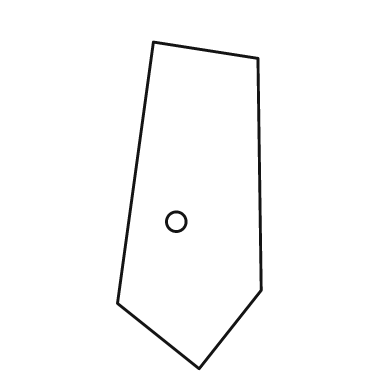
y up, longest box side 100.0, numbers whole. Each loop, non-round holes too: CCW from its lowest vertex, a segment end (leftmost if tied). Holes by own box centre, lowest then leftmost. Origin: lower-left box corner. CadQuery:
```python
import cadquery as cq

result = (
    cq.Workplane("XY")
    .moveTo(25.0, 0.0)
    .lineTo(44.0, 24.0)
    .lineTo(43.0, 95.0)
    .lineTo(11.0, 100.0)
    .lineTo(0.0, 20.0)
    .close()
    .moveTo(18.0, 45.0)
    .circle(3.0)
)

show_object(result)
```